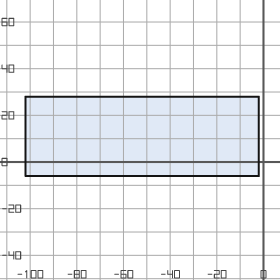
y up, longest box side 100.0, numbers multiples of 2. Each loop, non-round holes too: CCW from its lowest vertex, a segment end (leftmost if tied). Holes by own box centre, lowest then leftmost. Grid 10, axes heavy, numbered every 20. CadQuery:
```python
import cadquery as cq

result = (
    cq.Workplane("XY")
    .moveTo(-102.0, -6.0)
    .lineTo(-2.0, -6.0)
    .lineTo(-2.0, 28.0)
    .lineTo(-102.0, 28.0)
    .close()
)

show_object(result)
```